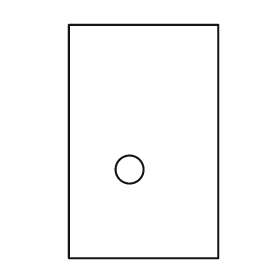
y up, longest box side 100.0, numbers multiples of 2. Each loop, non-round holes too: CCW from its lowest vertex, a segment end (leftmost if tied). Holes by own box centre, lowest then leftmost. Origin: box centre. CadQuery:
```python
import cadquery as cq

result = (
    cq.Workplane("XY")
    .moveTo(-32.0, -50.0)
    .lineTo(32.0, -50.0)
    .lineTo(32.0, 50.0)
    .lineTo(-32.0, 50.0)
    .close()
    .moveTo(-6.0, -12.0)
    .circle(6.0)
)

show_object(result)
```